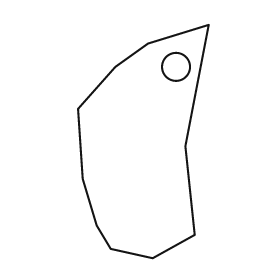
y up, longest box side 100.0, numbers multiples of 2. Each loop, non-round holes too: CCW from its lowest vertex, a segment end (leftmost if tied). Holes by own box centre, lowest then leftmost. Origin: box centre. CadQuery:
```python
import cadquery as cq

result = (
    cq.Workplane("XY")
    .moveTo(4.0, -50.0)
    .lineTo(22.0, -40.0)
    .lineTo(18.0, -2.0)
    .lineTo(28.0, 50.0)
    .lineTo(2.0, 42.0)
    .lineTo(-12.0, 32.0)
    .lineTo(-28.0, 14.0)
    .lineTo(-26.0, -16.0)
    .lineTo(-20.0, -36.0)
    .lineTo(-14.0, -46.0)
    .close()
    .moveTo(14.0, 32.0)
    .circle(6.0)
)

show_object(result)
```